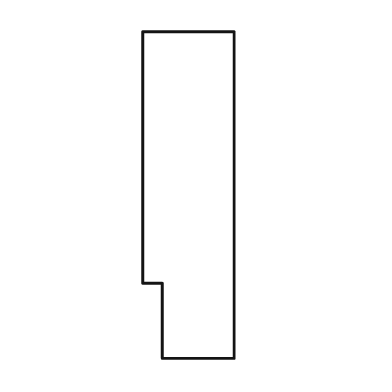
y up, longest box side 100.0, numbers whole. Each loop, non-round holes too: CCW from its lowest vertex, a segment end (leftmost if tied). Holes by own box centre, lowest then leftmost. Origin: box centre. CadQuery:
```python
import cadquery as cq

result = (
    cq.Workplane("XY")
    .moveTo(-8.0, -50.0)
    .lineTo(14.0, -50.0)
    .lineTo(14.0, 50.0)
    .lineTo(-14.0, 50.0)
    .lineTo(-14.0, -27.0)
    .lineTo(-8.0, -27.0)
    .close()
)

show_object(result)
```